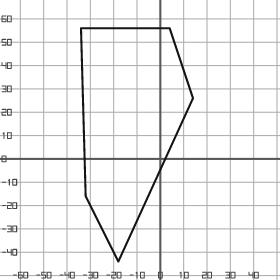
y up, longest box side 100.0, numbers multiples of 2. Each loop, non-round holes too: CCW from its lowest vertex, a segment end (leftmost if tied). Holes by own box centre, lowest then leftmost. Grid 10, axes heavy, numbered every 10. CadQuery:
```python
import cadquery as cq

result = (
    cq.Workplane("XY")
    .moveTo(-18.0, -44.0)
    .lineTo(14.0, 26.0)
    .lineTo(4.0, 56.0)
    .lineTo(-34.0, 56.0)
    .lineTo(-32.0, -16.0)
    .close()
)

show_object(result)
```